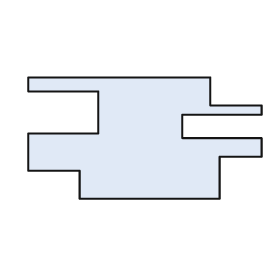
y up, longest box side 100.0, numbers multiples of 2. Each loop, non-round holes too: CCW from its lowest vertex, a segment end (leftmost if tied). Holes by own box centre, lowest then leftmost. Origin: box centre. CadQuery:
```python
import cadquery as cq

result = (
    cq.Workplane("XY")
    .moveTo(-28.0, -26.0)
    .lineTo(32.0, -26.0)
    .lineTo(32.0, -8.0)
    .lineTo(50.0, -8.0)
    .lineTo(50.0, 0.0)
    .lineTo(16.0, 0.0)
    .lineTo(16.0, 10.0)
    .lineTo(50.0, 10.0)
    .lineTo(50.0, 14.0)
    .lineTo(28.0, 14.0)
    .lineTo(28.0, 26.0)
    .lineTo(-50.0, 26.0)
    .lineTo(-50.0, 20.0)
    .lineTo(-20.0, 20.0)
    .lineTo(-20.0, 2.0)
    .lineTo(-50.0, 2.0)
    .lineTo(-50.0, -14.0)
    .lineTo(-28.0, -14.0)
    .close()
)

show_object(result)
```